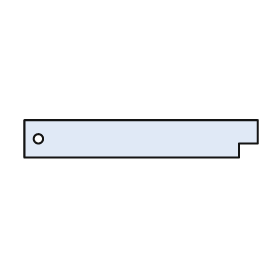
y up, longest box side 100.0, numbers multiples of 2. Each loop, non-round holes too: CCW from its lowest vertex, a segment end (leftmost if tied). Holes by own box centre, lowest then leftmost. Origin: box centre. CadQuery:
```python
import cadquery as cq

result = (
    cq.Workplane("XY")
    .moveTo(-50.0, -8.0)
    .lineTo(42.0, -8.0)
    .lineTo(42.0, -2.0)
    .lineTo(50.0, -2.0)
    .lineTo(50.0, 8.0)
    .lineTo(-50.0, 8.0)
    .close()
    .moveTo(-44.0, 0.0)
    .circle(2.0)
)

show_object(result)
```